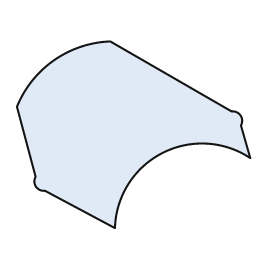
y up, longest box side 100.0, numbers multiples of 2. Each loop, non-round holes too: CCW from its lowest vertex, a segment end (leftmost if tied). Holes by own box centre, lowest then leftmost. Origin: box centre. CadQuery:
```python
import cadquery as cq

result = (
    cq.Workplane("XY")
    .moveTo(-8.0, -40.0)
    .threePointArc((12.0, -8.0), (50.0, -10.0))
    .lineTo(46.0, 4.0)
    .threePointArc((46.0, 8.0), (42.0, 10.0))
    .lineTo(-10.0, 40.0)
    .threePointArc((-34.0, 32.0), (-50.0, 12.0))
    .lineTo(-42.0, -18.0)
    .threePointArc((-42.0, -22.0), (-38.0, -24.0))
    .close()
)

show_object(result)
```